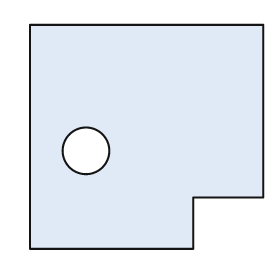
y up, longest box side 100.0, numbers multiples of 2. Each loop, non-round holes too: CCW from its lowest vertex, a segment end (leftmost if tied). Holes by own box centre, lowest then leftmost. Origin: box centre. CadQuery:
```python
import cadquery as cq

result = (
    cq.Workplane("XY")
    .moveTo(-50.0, -48.0)
    .lineTo(20.0, -48.0)
    .lineTo(20.0, -26.0)
    .lineTo(50.0, -26.0)
    .lineTo(50.0, 48.0)
    .lineTo(-50.0, 48.0)
    .close()
    .moveTo(-26.0, -6.0)
    .circle(10.0)
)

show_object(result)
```